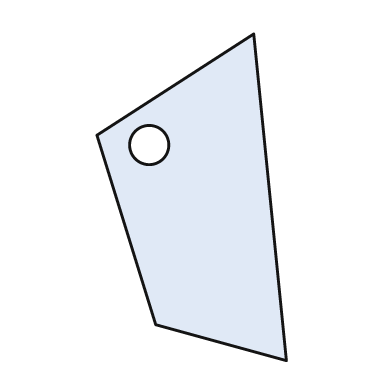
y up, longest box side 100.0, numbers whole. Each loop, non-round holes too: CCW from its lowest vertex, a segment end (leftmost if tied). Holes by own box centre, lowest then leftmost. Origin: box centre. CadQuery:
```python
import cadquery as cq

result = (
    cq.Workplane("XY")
    .moveTo(29.0, -50.0)
    .lineTo(19.0, 50.0)
    .lineTo(-29.0, 19.0)
    .lineTo(-11.0, -39.0)
    .close()
    .moveTo(-13.0, 16.0)
    .circle(6.0)
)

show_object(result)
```